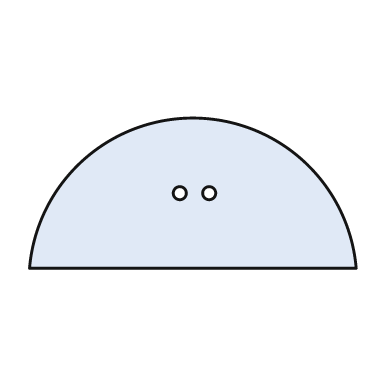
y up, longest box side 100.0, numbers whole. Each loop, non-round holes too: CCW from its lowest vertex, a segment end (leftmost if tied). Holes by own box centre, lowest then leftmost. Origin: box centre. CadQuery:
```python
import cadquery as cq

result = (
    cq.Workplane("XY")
    .moveTo(-50.0, -23.0)
    .lineTo(50.0, -23.0)
    .threePointArc((0.0, 23.0), (-50.0, -23.0))
    .close()
    .moveTo(-4.0, 0.0)
    .circle(2.0)
    .moveTo(5.0, 0.0)
    .circle(2.0)
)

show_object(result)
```